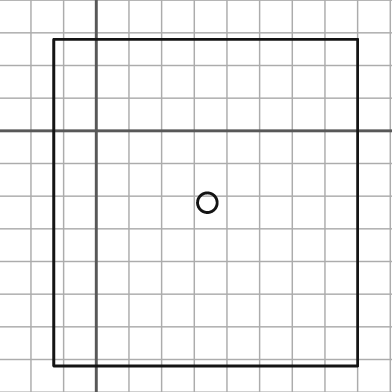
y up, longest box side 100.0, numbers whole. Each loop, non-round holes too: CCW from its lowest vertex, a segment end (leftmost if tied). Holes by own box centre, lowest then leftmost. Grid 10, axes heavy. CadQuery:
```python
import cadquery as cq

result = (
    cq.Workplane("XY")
    .moveTo(-13.0, -72.0)
    .lineTo(80.0, -72.0)
    .lineTo(80.0, 28.0)
    .lineTo(-13.0, 28.0)
    .close()
    .moveTo(34.0, -22.0)
    .circle(3.0)
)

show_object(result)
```